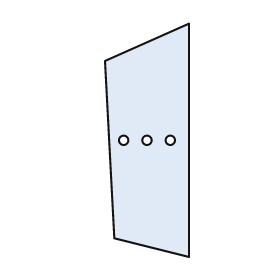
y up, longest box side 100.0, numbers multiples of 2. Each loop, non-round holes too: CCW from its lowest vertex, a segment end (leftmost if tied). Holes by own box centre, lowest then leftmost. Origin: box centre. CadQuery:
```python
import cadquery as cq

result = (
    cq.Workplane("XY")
    .moveTo(18.0, -50.0)
    .lineTo(18.0, 50.0)
    .lineTo(-18.0, 34.0)
    .lineTo(-14.0, -42.0)
    .close()
    .moveTo(-10.0, 0.0)
    .circle(2.0)
    .moveTo(0.0, 0.0)
    .circle(2.0)
    .moveTo(10.0, 0.0)
    .circle(2.0)
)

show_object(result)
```